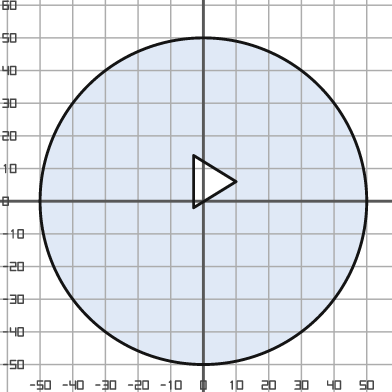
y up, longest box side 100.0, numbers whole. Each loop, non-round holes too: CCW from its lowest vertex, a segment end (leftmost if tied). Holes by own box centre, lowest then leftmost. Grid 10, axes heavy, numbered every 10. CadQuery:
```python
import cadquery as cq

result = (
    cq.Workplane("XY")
    .moveTo(0.0, 0.0)
    .circle(50.0)
    .moveTo(-3.0, -2.0)
    .lineTo(10.0, 6.0)
    .lineTo(-3.0, 14.0)
    .close()
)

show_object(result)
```